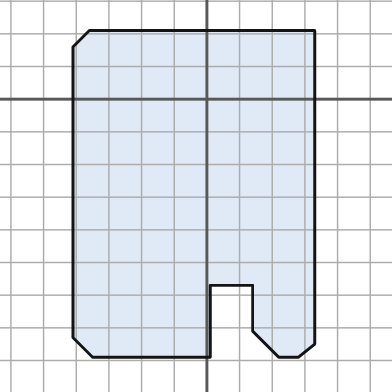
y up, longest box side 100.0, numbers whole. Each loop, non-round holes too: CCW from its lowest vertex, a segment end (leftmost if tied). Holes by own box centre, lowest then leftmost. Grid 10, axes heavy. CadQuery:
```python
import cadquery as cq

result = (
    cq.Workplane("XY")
    .moveTo(-35.0, -79.0)
    .lineTo(1.0, -79.0)
    .lineTo(1.0, -57.0)
    .lineTo(14.0, -57.0)
    .lineTo(14.0, -71.0)
    .lineTo(22.0, -79.0)
    .lineTo(28.0, -79.0)
    .lineTo(33.0, -75.0)
    .lineTo(33.0, 21.0)
    .lineTo(-36.0, 21.0)
    .lineTo(-41.0, 16.0)
    .lineTo(-41.0, -73.0)
    .close()
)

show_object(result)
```